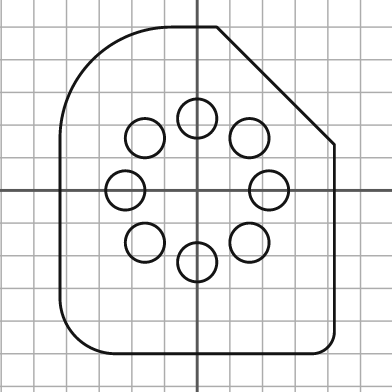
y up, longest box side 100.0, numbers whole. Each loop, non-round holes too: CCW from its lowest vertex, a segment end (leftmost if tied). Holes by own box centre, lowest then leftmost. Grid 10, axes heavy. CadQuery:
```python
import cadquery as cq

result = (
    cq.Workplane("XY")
    .moveTo(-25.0, -50.0)
    .lineTo(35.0, -50.0)
    .threePointArc((40.0, -48.0), (42.0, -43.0))
    .lineTo(42.0, 14.0)
    .lineTo(6.0, 50.0)
    .lineTo(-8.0, 50.0)
    .threePointArc((-32.0, 40.0), (-42.0, 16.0))
    .lineTo(-42.0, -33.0)
    .threePointArc((-37.0, -45.0), (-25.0, -50.0))
    .close()
    .moveTo(0.0, -22.0)
    .circle(6.0)
    .moveTo(-16.0, -16.0)
    .circle(6.0)
    .moveTo(16.0, -16.0)
    .circle(6.0)
    .moveTo(-22.0, 0.0)
    .circle(6.0)
    .moveTo(22.0, 0.0)
    .circle(6.0)
    .moveTo(-16.0, 16.0)
    .circle(6.0)
    .moveTo(16.0, 16.0)
    .circle(6.0)
    .moveTo(0.0, 22.0)
    .circle(6.0)
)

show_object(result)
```